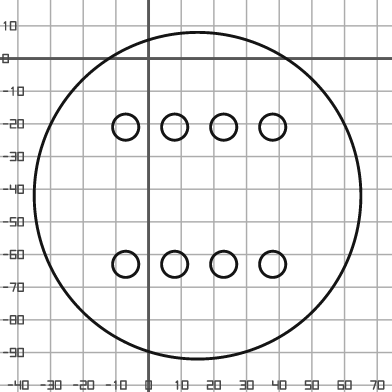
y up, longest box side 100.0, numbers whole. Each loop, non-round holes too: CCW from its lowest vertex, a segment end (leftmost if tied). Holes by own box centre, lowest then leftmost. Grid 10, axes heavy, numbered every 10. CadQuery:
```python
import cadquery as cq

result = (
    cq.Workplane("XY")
    .moveTo(15.0, -42.0)
    .circle(50.0)
    .moveTo(-7.0, -63.0)
    .circle(4.0)
    .moveTo(8.0, -63.0)
    .circle(4.0)
    .moveTo(23.0, -63.0)
    .circle(4.0)
    .moveTo(38.0, -63.0)
    .circle(4.0)
    .moveTo(-7.0, -21.0)
    .circle(4.0)
    .moveTo(8.0, -21.0)
    .circle(4.0)
    .moveTo(23.0, -21.0)
    .circle(4.0)
    .moveTo(38.0, -21.0)
    .circle(4.0)
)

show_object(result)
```